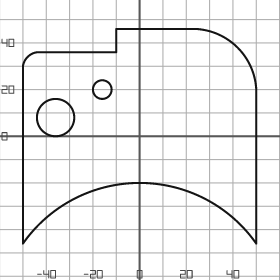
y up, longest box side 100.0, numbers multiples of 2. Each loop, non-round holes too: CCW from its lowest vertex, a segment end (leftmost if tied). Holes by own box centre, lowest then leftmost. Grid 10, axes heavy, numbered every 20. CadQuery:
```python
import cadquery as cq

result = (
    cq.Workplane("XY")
    .moveTo(-50.0, -46.0)
    .threePointArc((0.0, -20.0), (50.0, -46.0))
    .lineTo(50.0, 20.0)
    .threePointArc((42.0, 38.0), (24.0, 46.0))
    .lineTo(-10.0, 46.0)
    .lineTo(-10.0, 36.0)
    .lineTo(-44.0, 36.0)
    .threePointArc((-48.0, 34.0), (-50.0, 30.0))
    .close()
    .moveTo(-36.0, 8.0)
    .circle(8.0)
    .moveTo(-16.0, 20.0)
    .circle(4.0)
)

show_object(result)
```